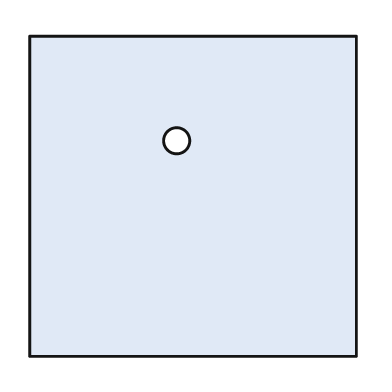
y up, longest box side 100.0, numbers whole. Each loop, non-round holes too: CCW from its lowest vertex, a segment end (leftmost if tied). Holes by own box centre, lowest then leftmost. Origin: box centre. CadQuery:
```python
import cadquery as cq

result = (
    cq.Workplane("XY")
    .moveTo(-50.0, -49.0)
    .lineTo(50.0, -49.0)
    .lineTo(50.0, 49.0)
    .lineTo(-50.0, 49.0)
    .close()
    .moveTo(-5.0, 17.0)
    .circle(4.0)
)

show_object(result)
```